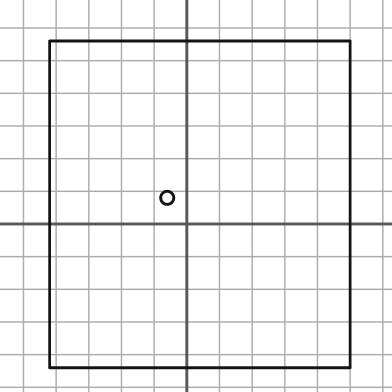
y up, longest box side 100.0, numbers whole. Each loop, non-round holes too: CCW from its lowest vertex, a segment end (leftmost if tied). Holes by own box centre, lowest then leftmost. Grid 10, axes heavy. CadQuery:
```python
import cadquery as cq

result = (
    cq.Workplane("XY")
    .moveTo(-42.0, -44.0)
    .lineTo(50.0, -44.0)
    .lineTo(50.0, 56.0)
    .lineTo(-42.0, 56.0)
    .close()
    .moveTo(-6.0, 8.0)
    .circle(2.0)
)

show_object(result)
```